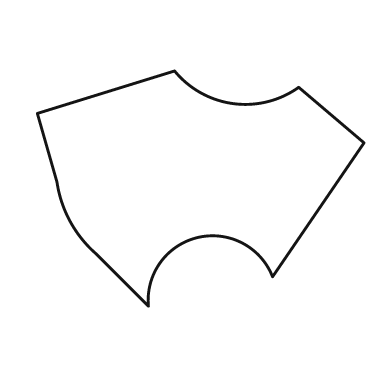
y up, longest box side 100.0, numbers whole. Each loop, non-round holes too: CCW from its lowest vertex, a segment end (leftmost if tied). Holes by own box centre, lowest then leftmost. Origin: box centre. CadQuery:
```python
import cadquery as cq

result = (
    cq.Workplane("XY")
    .moveTo(-16.0, -36.0)
    .threePointArc((-1.0, -15.0), (22.0, -27.0))
    .lineTo(50.0, 14.0)
    .lineTo(30.0, 31.0)
    .threePointArc((10.0, 26.0), (-8.0, 36.0))
    .lineTo(-50.0, 23.0)
    .lineTo(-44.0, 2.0)
    .threePointArc((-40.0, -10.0), (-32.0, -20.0))
    .close()
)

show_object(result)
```